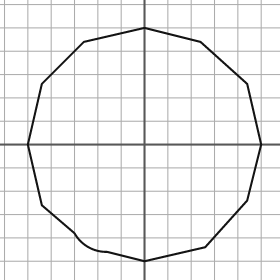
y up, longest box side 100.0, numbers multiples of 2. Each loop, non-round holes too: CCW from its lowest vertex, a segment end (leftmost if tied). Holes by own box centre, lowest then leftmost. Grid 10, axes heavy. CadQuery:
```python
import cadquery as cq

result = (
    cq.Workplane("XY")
    .moveTo(0.0, -50.0)
    .lineTo(26.0, -44.0)
    .lineTo(44.0, -24.0)
    .lineTo(50.0, 0.0)
    .lineTo(44.0, 26.0)
    .lineTo(24.0, 44.0)
    .lineTo(0.0, 50.0)
    .lineTo(-26.0, 44.0)
    .lineTo(-44.0, 26.0)
    .lineTo(-50.0, 0.0)
    .lineTo(-44.0, -26.0)
    .lineTo(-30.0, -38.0)
    .threePointArc((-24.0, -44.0), (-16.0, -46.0))
    .close()
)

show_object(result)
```